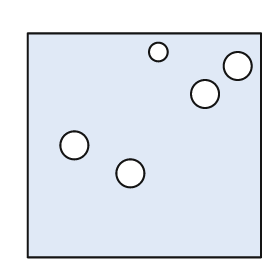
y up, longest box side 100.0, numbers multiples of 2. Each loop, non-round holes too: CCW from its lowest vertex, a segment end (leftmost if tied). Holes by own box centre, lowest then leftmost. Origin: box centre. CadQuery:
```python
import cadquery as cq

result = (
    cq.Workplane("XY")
    .moveTo(-50.0, -48.0)
    .lineTo(50.0, -48.0)
    .lineTo(50.0, 48.0)
    .lineTo(-50.0, 48.0)
    .close()
    .moveTo(-6.0, -12.0)
    .circle(6.0)
    .moveTo(-30.0, 0.0)
    .circle(6.0)
    .moveTo(26.0, 22.0)
    .circle(6.0)
    .moveTo(40.0, 34.0)
    .circle(6.0)
    .moveTo(6.0, 40.0)
    .circle(4.0)
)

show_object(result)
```